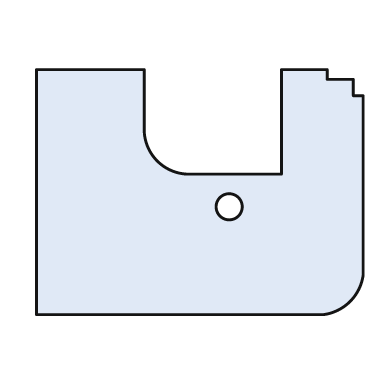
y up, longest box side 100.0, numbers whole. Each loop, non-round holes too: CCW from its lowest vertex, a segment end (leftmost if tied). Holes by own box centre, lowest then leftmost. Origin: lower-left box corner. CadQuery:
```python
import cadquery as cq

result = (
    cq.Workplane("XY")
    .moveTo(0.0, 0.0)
    .lineTo(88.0, 0.0)
    .threePointArc((96.0, 4.0), (100.0, 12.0))
    .lineTo(100.0, 67.0)
    .lineTo(97.0, 67.0)
    .lineTo(97.0, 72.0)
    .lineTo(89.0, 72.0)
    .lineTo(89.0, 75.0)
    .lineTo(75.0, 75.0)
    .lineTo(75.0, 43.0)
    .lineTo(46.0, 43.0)
    .threePointArc((37.0, 47.0), (33.0, 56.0))
    .lineTo(33.0, 75.0)
    .lineTo(0.0, 75.0)
    .close()
    .moveTo(59.0, 33.0)
    .circle(4.0)
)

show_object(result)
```